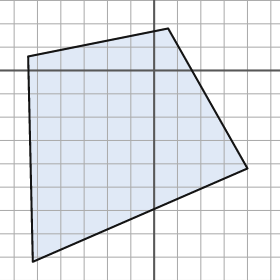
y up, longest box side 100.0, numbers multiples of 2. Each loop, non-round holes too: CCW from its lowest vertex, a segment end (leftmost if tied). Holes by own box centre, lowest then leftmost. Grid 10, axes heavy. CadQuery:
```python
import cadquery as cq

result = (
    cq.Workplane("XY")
    .moveTo(-52.0, -82.0)
    .lineTo(40.0, -42.0)
    .lineTo(6.0, 18.0)
    .lineTo(-54.0, 6.0)
    .close()
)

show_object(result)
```